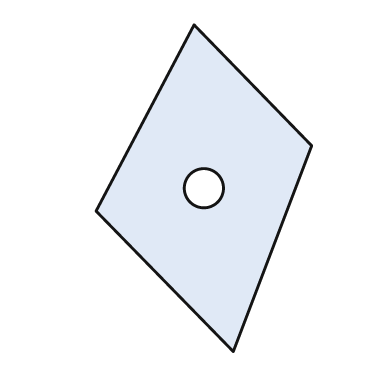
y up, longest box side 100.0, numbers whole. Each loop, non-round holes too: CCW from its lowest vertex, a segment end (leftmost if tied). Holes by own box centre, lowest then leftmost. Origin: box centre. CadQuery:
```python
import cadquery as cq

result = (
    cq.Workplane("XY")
    .moveTo(9.0, -50.0)
    .lineTo(33.0, 13.0)
    .lineTo(-3.0, 50.0)
    .lineTo(-33.0, -7.0)
    .close()
    .moveTo(0.0, 0.0)
    .circle(6.0)
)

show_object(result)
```